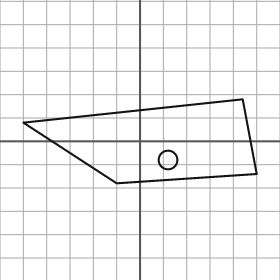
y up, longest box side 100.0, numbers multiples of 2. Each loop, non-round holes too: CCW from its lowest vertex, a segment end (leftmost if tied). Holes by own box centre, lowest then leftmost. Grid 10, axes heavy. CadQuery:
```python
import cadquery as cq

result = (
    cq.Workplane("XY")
    .moveTo(-10.0, -18.0)
    .lineTo(50.0, -14.0)
    .lineTo(44.0, 18.0)
    .lineTo(-50.0, 8.0)
    .close()
    .moveTo(12.0, -8.0)
    .circle(4.0)
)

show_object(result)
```